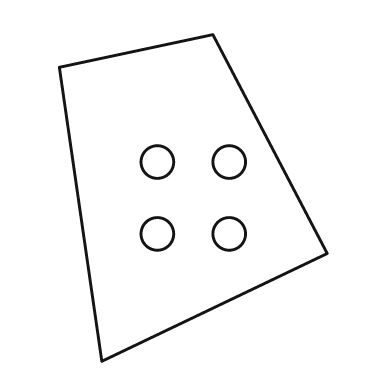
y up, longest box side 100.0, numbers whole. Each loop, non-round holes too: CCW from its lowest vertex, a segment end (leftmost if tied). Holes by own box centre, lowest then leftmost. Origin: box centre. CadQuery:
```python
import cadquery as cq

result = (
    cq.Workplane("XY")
    .moveTo(-28.0, -50.0)
    .lineTo(41.0, -17.0)
    .lineTo(6.0, 50.0)
    .lineTo(-41.0, 40.0)
    .close()
    .moveTo(-11.0, -11.0)
    .circle(5.0)
    .moveTo(11.0, -11.0)
    .circle(5.0)
    .moveTo(-11.0, 11.0)
    .circle(5.0)
    .moveTo(11.0, 11.0)
    .circle(5.0)
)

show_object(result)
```